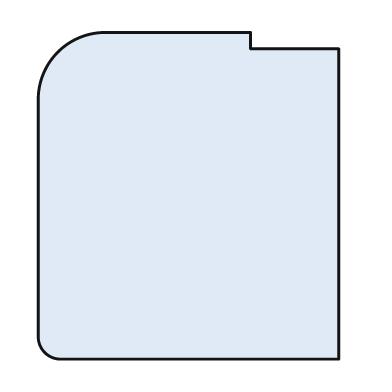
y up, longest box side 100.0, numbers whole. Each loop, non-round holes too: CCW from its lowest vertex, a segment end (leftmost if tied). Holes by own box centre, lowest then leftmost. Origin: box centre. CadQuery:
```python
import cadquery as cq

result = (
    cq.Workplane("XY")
    .moveTo(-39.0, -50.0)
    .lineTo(46.0, -50.0)
    .lineTo(46.0, 45.0)
    .lineTo(19.0, 45.0)
    .lineTo(19.0, 50.0)
    .lineTo(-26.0, 50.0)
    .threePointArc((-40.0, 44.0), (-46.0, 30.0))
    .lineTo(-46.0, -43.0)
    .threePointArc((-44.0, -48.0), (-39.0, -50.0))
    .close()
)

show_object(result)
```